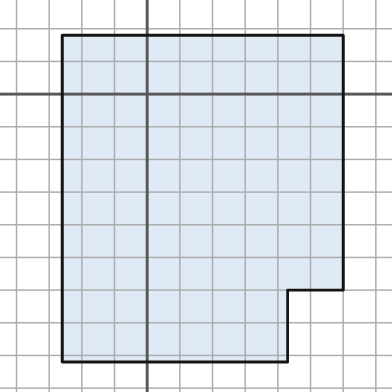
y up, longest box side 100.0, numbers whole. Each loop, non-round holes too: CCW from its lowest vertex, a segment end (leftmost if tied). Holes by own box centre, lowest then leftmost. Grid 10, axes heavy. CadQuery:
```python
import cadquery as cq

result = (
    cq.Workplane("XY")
    .moveTo(-26.0, -82.0)
    .lineTo(43.0, -82.0)
    .lineTo(43.0, -60.0)
    .lineTo(60.0, -60.0)
    .lineTo(60.0, 18.0)
    .lineTo(-26.0, 18.0)
    .close()
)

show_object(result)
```